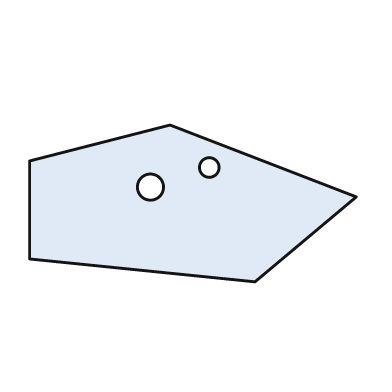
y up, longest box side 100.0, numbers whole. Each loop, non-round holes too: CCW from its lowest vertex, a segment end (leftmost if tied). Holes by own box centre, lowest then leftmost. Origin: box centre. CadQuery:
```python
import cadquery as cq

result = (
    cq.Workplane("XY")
    .moveTo(19.0, -24.0)
    .lineTo(50.0, 2.0)
    .lineTo(-7.0, 24.0)
    .lineTo(-50.0, 13.0)
    .lineTo(-50.0, -17.0)
    .close()
    .moveTo(-13.0, 5.0)
    .circle(4.0)
    .moveTo(5.0, 11.0)
    .circle(3.0)
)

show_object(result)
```